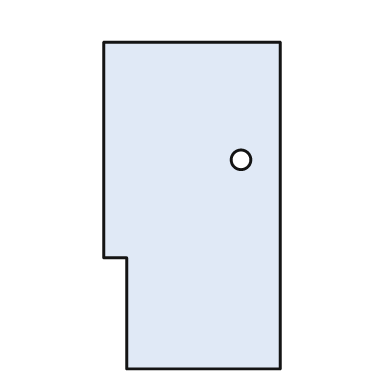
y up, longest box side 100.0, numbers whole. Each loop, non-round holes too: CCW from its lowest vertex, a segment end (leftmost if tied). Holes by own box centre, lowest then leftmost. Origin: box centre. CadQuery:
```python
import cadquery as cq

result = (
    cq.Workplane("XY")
    .moveTo(-20.0, -50.0)
    .lineTo(27.0, -50.0)
    .lineTo(27.0, 50.0)
    .lineTo(-27.0, 50.0)
    .lineTo(-27.0, -16.0)
    .lineTo(-20.0, -16.0)
    .close()
    .moveTo(15.0, 14.0)
    .circle(3.0)
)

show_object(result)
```